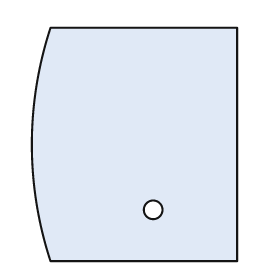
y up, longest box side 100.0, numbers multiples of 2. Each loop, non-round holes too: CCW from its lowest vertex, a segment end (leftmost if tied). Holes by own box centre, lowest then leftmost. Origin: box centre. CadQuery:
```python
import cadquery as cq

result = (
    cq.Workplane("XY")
    .moveTo(-36.0, -50.0)
    .lineTo(44.0, -50.0)
    .lineTo(44.0, 50.0)
    .lineTo(-36.0, 50.0)
    .threePointArc((-44.0, 0.0), (-36.0, -50.0))
    .close()
    .moveTo(8.0, -28.0)
    .circle(4.0)
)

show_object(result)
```